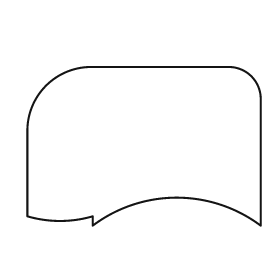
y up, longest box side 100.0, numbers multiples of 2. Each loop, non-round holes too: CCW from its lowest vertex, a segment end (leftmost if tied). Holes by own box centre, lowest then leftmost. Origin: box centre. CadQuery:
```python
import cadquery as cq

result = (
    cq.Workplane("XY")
    .moveTo(-22.0, -34.0)
    .threePointArc((14.0, -22.0), (50.0, -34.0))
    .lineTo(50.0, 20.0)
    .threePointArc((46.0, 30.0), (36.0, 34.0))
    .lineTo(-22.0, 34.0)
    .threePointArc((-42.0, 26.0), (-50.0, 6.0))
    .lineTo(-50.0, -30.0)
    .threePointArc((-36.0, -32.0), (-22.0, -30.0))
    .close()
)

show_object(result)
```